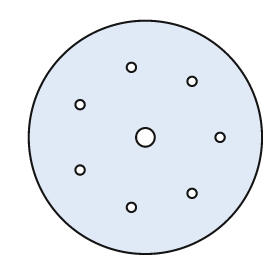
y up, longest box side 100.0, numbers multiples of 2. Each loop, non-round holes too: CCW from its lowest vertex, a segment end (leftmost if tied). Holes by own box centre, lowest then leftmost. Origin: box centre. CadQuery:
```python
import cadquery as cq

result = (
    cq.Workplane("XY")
    .moveTo(0.0, 0.0)
    .circle(50.0)
    .moveTo(-6.0, -30.0)
    .circle(2.0)
    .moveTo(20.0, -24.0)
    .circle(2.0)
    .moveTo(-28.0, -14.0)
    .circle(2.0)
    .moveTo(0.0, 0.0)
    .circle(4.0)
    .moveTo(32.0, 0.0)
    .circle(2.0)
    .moveTo(-28.0, 14.0)
    .circle(2.0)
    .moveTo(20.0, 24.0)
    .circle(2.0)
    .moveTo(-6.0, 30.0)
    .circle(2.0)
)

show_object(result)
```